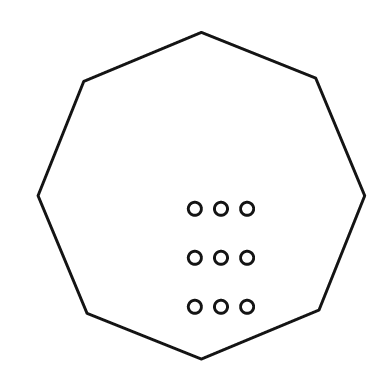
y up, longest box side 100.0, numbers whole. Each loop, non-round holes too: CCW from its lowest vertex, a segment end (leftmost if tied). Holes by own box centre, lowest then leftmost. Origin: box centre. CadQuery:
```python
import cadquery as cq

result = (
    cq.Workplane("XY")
    .moveTo(0.0, -50.0)
    .lineTo(36.0, -35.0)
    .lineTo(50.0, 0.0)
    .lineTo(35.0, 36.0)
    .lineTo(0.0, 50.0)
    .lineTo(-36.0, 35.0)
    .lineTo(-50.0, 0.0)
    .lineTo(-35.0, -36.0)
    .close()
    .moveTo(-2.0, -34.0)
    .circle(2.0)
    .moveTo(6.0, -34.0)
    .circle(2.0)
    .moveTo(14.0, -34.0)
    .circle(2.0)
    .moveTo(-2.0, -19.0)
    .circle(2.0)
    .moveTo(6.0, -19.0)
    .circle(2.0)
    .moveTo(14.0, -19.0)
    .circle(2.0)
    .moveTo(-2.0, -4.0)
    .circle(2.0)
    .moveTo(6.0, -4.0)
    .circle(2.0)
    .moveTo(14.0, -4.0)
    .circle(2.0)
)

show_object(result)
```